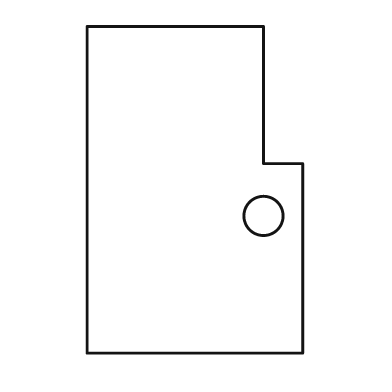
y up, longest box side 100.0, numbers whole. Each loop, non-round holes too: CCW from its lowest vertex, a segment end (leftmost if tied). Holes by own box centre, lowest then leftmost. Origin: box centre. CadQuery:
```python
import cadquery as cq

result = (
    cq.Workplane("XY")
    .moveTo(-33.0, -50.0)
    .lineTo(33.0, -50.0)
    .lineTo(33.0, 8.0)
    .lineTo(21.0, 8.0)
    .lineTo(21.0, 50.0)
    .lineTo(-33.0, 50.0)
    .close()
    .moveTo(21.0, -8.0)
    .circle(6.0)
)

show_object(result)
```